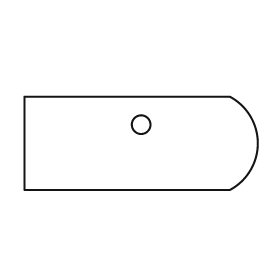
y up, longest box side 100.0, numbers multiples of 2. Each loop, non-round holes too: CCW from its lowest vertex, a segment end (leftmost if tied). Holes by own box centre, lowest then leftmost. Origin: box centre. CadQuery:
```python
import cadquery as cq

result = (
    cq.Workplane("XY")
    .moveTo(-50.0, -20.0)
    .lineTo(38.0, -20.0)
    .threePointArc((50.0, 0.0), (38.0, 20.0))
    .lineTo(-50.0, 20.0)
    .close()
    .moveTo(0.0, 8.0)
    .circle(4.0)
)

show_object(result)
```